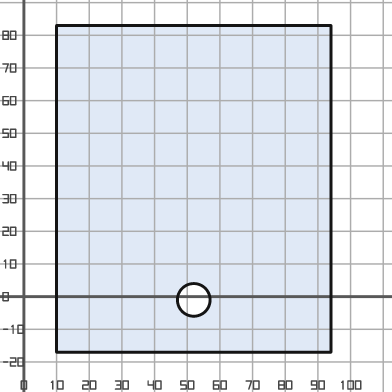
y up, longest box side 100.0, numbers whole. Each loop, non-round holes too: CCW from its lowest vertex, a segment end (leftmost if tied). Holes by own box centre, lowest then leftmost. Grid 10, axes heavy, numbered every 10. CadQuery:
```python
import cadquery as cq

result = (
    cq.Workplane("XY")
    .moveTo(10.0, -17.0)
    .lineTo(94.0, -17.0)
    .lineTo(94.0, 83.0)
    .lineTo(10.0, 83.0)
    .close()
    .moveTo(52.0, -1.0)
    .circle(5.0)
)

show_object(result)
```